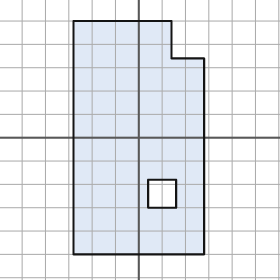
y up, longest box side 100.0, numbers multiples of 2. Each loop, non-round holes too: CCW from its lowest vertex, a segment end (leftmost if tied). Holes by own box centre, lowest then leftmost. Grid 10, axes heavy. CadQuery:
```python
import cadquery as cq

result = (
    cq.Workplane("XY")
    .moveTo(-28.0, -50.0)
    .lineTo(28.0, -50.0)
    .lineTo(28.0, 34.0)
    .lineTo(14.0, 34.0)
    .lineTo(14.0, 50.0)
    .lineTo(-28.0, 50.0)
    .close()
    .moveTo(4.0, -30.0)
    .lineTo(16.0, -30.0)
    .lineTo(16.0, -18.0)
    .lineTo(4.0, -18.0)
    .close()
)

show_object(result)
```